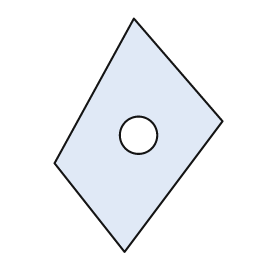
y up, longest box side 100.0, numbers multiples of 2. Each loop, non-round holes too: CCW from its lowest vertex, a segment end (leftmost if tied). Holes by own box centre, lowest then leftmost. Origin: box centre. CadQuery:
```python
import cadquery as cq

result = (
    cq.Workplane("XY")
    .moveTo(-6.0, -50.0)
    .lineTo(36.0, 6.0)
    .lineTo(-2.0, 50.0)
    .lineTo(-36.0, -12.0)
    .close()
    .moveTo(0.0, 0.0)
    .circle(8.0)
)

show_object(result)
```